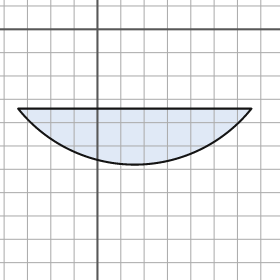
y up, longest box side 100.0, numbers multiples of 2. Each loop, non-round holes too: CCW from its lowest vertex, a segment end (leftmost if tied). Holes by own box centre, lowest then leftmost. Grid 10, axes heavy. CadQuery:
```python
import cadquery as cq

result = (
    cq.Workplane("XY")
    .moveTo(-34.0, -34.0)
    .threePointArc((16.0, -58.0), (66.0, -34.0))
    .close()
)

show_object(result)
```